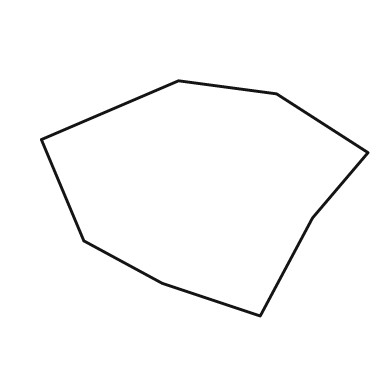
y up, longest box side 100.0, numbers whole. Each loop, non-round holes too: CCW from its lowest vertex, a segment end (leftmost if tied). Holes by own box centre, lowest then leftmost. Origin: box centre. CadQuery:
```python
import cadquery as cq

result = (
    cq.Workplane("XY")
    .moveTo(17.0, -36.0)
    .lineTo(33.0, -6.0)
    .lineTo(50.0, 14.0)
    .lineTo(22.0, 32.0)
    .lineTo(-8.0, 36.0)
    .lineTo(-50.0, 18.0)
    .lineTo(-37.0, -13.0)
    .lineTo(-13.0, -26.0)
    .close()
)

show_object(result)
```